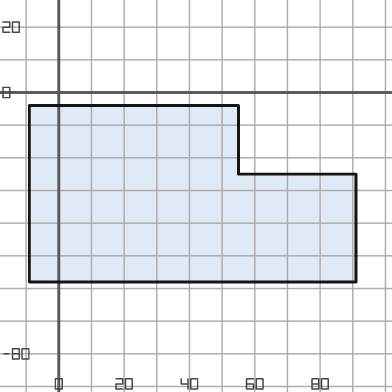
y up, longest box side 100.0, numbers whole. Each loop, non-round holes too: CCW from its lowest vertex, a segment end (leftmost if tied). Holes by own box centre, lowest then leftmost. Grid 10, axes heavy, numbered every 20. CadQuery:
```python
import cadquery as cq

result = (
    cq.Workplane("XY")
    .moveTo(-9.0, -58.0)
    .lineTo(91.0, -58.0)
    .lineTo(91.0, -25.0)
    .lineTo(55.0, -25.0)
    .lineTo(55.0, -4.0)
    .lineTo(-9.0, -4.0)
    .close()
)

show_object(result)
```